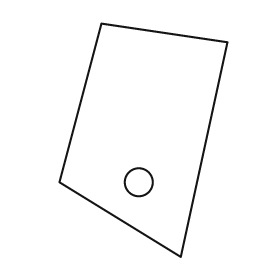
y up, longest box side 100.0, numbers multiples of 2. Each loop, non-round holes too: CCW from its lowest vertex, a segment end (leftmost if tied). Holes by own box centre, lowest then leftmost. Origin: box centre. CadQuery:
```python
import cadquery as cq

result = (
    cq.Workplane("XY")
    .moveTo(16.0, -50.0)
    .lineTo(36.0, 42.0)
    .lineTo(-18.0, 50.0)
    .lineTo(-36.0, -18.0)
    .close()
    .moveTo(-2.0, -18.0)
    .circle(6.0)
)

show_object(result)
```